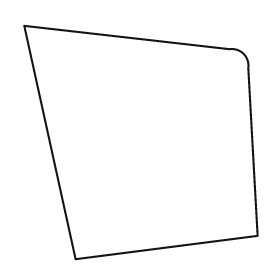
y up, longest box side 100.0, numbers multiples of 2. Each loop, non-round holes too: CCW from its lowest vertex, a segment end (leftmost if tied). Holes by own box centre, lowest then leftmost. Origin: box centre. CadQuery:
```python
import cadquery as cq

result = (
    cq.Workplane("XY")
    .moveTo(-28.0, -50.0)
    .lineTo(50.0, -40.0)
    .lineTo(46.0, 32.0)
    .threePointArc((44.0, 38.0), (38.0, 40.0))
    .lineTo(-50.0, 50.0)
    .close()
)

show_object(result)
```